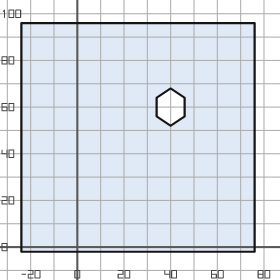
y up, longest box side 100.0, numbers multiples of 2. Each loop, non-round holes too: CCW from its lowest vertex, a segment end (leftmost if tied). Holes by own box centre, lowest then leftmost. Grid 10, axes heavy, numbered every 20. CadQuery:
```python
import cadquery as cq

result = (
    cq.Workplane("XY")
    .moveTo(-24.0, -2.0)
    .lineTo(76.0, -2.0)
    .lineTo(76.0, 96.0)
    .lineTo(-24.0, 96.0)
    .close()
    .moveTo(40.0, 52.0)
    .lineTo(46.0, 56.0)
    .lineTo(46.0, 64.0)
    .lineTo(40.0, 68.0)
    .lineTo(34.0, 64.0)
    .lineTo(34.0, 56.0)
    .close()
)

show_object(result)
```